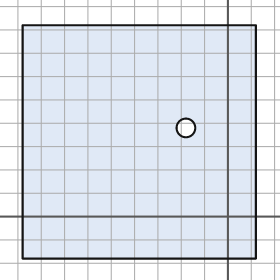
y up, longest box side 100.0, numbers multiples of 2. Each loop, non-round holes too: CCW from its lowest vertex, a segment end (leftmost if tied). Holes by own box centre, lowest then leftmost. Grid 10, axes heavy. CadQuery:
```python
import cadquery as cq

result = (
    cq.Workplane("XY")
    .moveTo(-88.0, -18.0)
    .lineTo(12.0, -18.0)
    .lineTo(12.0, 82.0)
    .lineTo(-88.0, 82.0)
    .close()
    .moveTo(-18.0, 38.0)
    .circle(4.0)
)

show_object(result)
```